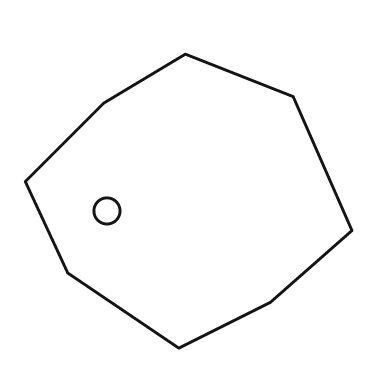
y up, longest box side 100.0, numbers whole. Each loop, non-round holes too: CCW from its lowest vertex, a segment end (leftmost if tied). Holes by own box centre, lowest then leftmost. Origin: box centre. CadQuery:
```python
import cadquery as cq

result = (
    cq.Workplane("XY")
    .moveTo(-3.0, -45.0)
    .lineTo(25.0, -31.0)
    .lineTo(50.0, -9.0)
    .lineTo(32.0, 32.0)
    .lineTo(-1.0, 45.0)
    .lineTo(-26.0, 30.0)
    .lineTo(-50.0, 6.0)
    .lineTo(-37.0, -22.0)
    .close()
    .moveTo(-25.0, -3.0)
    .circle(4.0)
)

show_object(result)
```